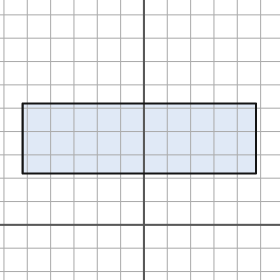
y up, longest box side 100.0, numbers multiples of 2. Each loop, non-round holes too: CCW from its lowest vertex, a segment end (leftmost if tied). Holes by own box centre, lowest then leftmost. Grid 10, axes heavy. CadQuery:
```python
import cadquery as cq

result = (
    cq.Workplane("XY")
    .moveTo(-52.0, 22.0)
    .lineTo(48.0, 22.0)
    .lineTo(48.0, 52.0)
    .lineTo(-52.0, 52.0)
    .close()
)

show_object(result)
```